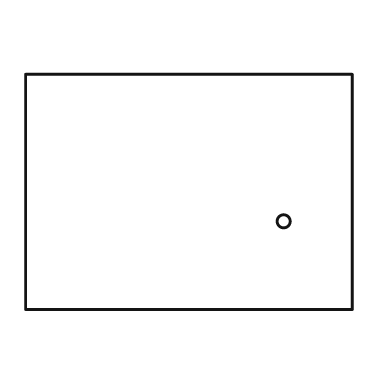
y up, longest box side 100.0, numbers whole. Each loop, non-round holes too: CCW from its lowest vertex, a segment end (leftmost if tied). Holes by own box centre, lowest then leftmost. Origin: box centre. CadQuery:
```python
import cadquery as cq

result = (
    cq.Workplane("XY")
    .moveTo(-50.0, -36.0)
    .lineTo(50.0, -36.0)
    .lineTo(50.0, 36.0)
    .lineTo(-50.0, 36.0)
    .close()
    .moveTo(29.0, -9.0)
    .circle(2.0)
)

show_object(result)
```